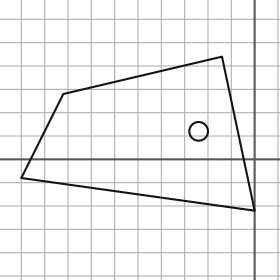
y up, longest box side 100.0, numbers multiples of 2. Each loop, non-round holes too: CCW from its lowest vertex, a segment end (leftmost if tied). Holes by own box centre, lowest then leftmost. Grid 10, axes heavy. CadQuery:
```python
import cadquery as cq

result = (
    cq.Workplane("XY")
    .moveTo(0.0, -22.0)
    .lineTo(-14.0, 44.0)
    .lineTo(-82.0, 28.0)
    .lineTo(-100.0, -8.0)
    .close()
    .moveTo(-24.0, 12.0)
    .circle(4.0)
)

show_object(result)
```